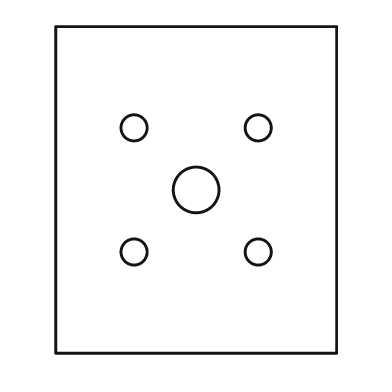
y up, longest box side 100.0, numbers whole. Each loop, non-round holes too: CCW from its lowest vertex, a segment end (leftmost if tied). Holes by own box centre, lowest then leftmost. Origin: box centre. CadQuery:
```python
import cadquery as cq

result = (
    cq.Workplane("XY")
    .moveTo(-43.0, -50.0)
    .lineTo(43.0, -50.0)
    .lineTo(43.0, 50.0)
    .lineTo(-43.0, 50.0)
    .close()
    .moveTo(-19.0, -19.0)
    .circle(4.0)
    .moveTo(19.0, -19.0)
    .circle(4.0)
    .moveTo(0.0, 0.0)
    .circle(7.0)
    .moveTo(-19.0, 19.0)
    .circle(4.0)
    .moveTo(19.0, 19.0)
    .circle(4.0)
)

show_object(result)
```